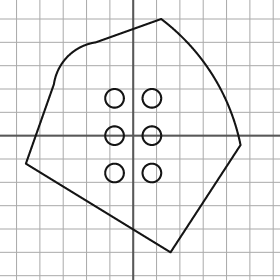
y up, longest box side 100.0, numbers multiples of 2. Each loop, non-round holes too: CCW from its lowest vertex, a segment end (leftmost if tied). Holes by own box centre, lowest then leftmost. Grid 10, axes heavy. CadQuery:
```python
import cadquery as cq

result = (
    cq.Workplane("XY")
    .moveTo(16.0, -50.0)
    .lineTo(46.0, -4.0)
    .threePointArc((34.0, 26.0), (12.0, 50.0))
    .lineTo(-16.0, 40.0)
    .threePointArc((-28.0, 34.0), (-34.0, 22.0))
    .lineTo(-46.0, -12.0)
    .close()
    .moveTo(-8.0, -16.0)
    .circle(4.0)
    .moveTo(8.0, -16.0)
    .circle(4.0)
    .moveTo(-8.0, 0.0)
    .circle(4.0)
    .moveTo(8.0, 0.0)
    .circle(4.0)
    .moveTo(-8.0, 16.0)
    .circle(4.0)
    .moveTo(8.0, 16.0)
    .circle(4.0)
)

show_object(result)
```